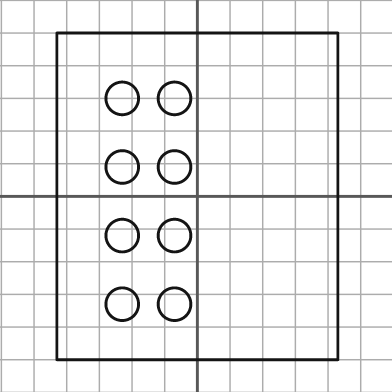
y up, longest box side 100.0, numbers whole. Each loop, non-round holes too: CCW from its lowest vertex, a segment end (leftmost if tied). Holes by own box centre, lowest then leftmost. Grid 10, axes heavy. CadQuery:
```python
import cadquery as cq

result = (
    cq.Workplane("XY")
    .moveTo(-43.0, -50.0)
    .lineTo(43.0, -50.0)
    .lineTo(43.0, 50.0)
    .lineTo(-43.0, 50.0)
    .close()
    .moveTo(-23.0, -33.0)
    .circle(5.0)
    .moveTo(-7.0, -33.0)
    .circle(5.0)
    .moveTo(-23.0, -12.0)
    .circle(5.0)
    .moveTo(-7.0, -12.0)
    .circle(5.0)
    .moveTo(-23.0, 9.0)
    .circle(5.0)
    .moveTo(-7.0, 9.0)
    .circle(5.0)
    .moveTo(-23.0, 30.0)
    .circle(5.0)
    .moveTo(-7.0, 30.0)
    .circle(5.0)
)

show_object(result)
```